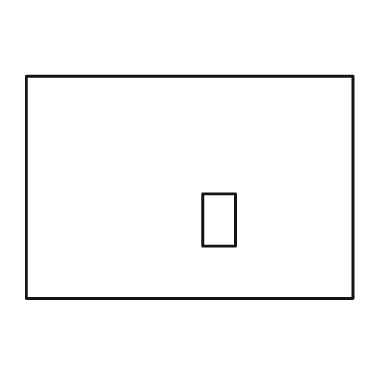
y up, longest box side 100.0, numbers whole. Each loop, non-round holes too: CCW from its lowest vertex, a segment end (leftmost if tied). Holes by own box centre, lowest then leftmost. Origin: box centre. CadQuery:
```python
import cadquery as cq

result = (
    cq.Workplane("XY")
    .moveTo(-50.0, -34.0)
    .lineTo(50.0, -34.0)
    .lineTo(50.0, 34.0)
    .lineTo(-50.0, 34.0)
    .close()
    .moveTo(4.0, -18.0)
    .lineTo(14.0, -18.0)
    .lineTo(14.0, -2.0)
    .lineTo(4.0, -2.0)
    .close()
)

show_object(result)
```